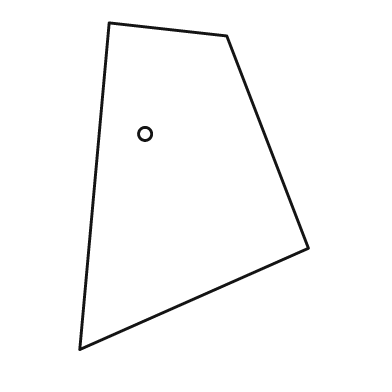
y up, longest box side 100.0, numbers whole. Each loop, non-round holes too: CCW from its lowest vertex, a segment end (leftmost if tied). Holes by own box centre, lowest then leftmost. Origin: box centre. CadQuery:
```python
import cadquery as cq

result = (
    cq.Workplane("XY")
    .moveTo(-35.0, -50.0)
    .lineTo(35.0, -19.0)
    .lineTo(10.0, 46.0)
    .lineTo(-26.0, 50.0)
    .close()
    .moveTo(-15.0, 16.0)
    .circle(2.0)
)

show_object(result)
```